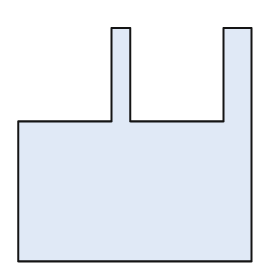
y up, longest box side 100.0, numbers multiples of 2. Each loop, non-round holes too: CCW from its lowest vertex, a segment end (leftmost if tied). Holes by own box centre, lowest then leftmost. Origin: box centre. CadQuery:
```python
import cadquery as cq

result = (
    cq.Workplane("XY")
    .moveTo(-50.0, -50.0)
    .lineTo(50.0, -50.0)
    .lineTo(50.0, 50.0)
    .lineTo(38.0, 50.0)
    .lineTo(38.0, 10.0)
    .lineTo(-2.0, 10.0)
    .lineTo(-2.0, 50.0)
    .lineTo(-10.0, 50.0)
    .lineTo(-10.0, 10.0)
    .lineTo(-50.0, 10.0)
    .close()
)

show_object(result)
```